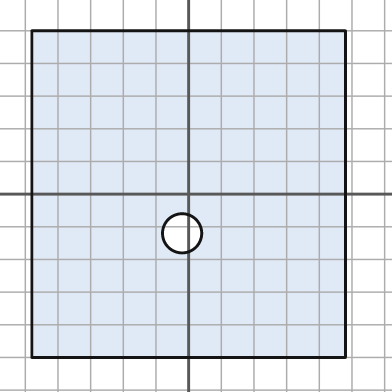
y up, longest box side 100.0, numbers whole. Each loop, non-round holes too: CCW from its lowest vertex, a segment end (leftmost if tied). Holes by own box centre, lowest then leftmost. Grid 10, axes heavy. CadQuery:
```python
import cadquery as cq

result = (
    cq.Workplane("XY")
    .moveTo(-48.0, -50.0)
    .lineTo(48.0, -50.0)
    .lineTo(48.0, 50.0)
    .lineTo(-48.0, 50.0)
    .close()
    .moveTo(-2.0, -12.0)
    .circle(6.0)
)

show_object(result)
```